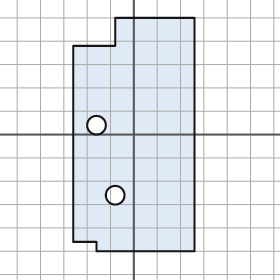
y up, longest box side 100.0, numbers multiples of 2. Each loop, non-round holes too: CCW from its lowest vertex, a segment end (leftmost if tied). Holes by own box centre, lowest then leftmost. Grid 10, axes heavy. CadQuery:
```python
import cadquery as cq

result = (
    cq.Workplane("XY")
    .moveTo(-16.0, -50.0)
    .lineTo(26.0, -50.0)
    .lineTo(26.0, 50.0)
    .lineTo(-8.0, 50.0)
    .lineTo(-8.0, 38.0)
    .lineTo(-26.0, 38.0)
    .lineTo(-26.0, -46.0)
    .lineTo(-16.0, -46.0)
    .close()
    .moveTo(-8.0, -26.0)
    .circle(4.0)
    .moveTo(-16.0, 4.0)
    .circle(4.0)
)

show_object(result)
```